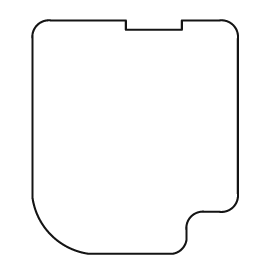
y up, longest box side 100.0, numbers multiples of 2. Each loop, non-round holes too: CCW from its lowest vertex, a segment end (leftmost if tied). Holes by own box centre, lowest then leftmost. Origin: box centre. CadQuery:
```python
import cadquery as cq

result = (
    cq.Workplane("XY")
    .moveTo(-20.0, -50.0)
    .lineTo(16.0, -50.0)
    .threePointArc((20.0, -48.0), (22.0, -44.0))
    .lineTo(22.0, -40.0)
    .threePointArc((24.0, -34.0), (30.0, -32.0))
    .lineTo(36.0, -32.0)
    .threePointArc((42.0, -30.0), (44.0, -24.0))
    .lineTo(44.0, 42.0)
    .threePointArc((42.0, 48.0), (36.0, 50.0))
    .lineTo(20.0, 50.0)
    .lineTo(20.0, 46.0)
    .lineTo(-4.0, 46.0)
    .lineTo(-4.0, 50.0)
    .lineTo(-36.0, 50.0)
    .threePointArc((-42.0, 48.0), (-44.0, 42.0))
    .lineTo(-44.0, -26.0)
    .threePointArc((-36.0, -42.0), (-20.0, -50.0))
    .close()
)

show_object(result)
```